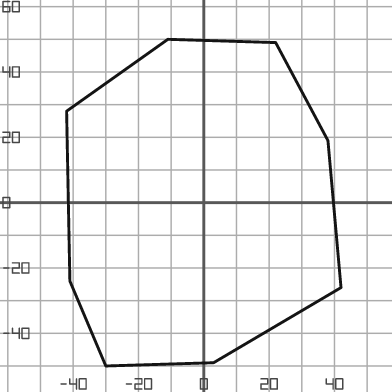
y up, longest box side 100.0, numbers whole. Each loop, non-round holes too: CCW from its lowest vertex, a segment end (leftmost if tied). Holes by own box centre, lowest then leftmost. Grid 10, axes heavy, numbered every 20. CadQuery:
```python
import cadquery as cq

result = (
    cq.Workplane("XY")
    .moveTo(-30.0, -50.0)
    .lineTo(3.0, -49.0)
    .lineTo(42.0, -26.0)
    .lineTo(38.0, 19.0)
    .lineTo(22.0, 49.0)
    .lineTo(-11.0, 50.0)
    .lineTo(-42.0, 28.0)
    .lineTo(-41.0, -24.0)
    .close()
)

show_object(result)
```